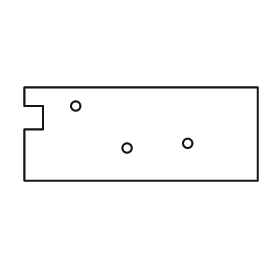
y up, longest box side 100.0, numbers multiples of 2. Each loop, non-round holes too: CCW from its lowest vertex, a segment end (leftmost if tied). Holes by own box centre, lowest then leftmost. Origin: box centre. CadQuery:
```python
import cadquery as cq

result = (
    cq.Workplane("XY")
    .moveTo(-50.0, -20.0)
    .lineTo(50.0, -20.0)
    .lineTo(50.0, 20.0)
    .lineTo(-50.0, 20.0)
    .lineTo(-50.0, 12.0)
    .lineTo(-42.0, 12.0)
    .lineTo(-42.0, 2.0)
    .lineTo(-50.0, 2.0)
    .close()
    .moveTo(-6.0, -6.0)
    .circle(2.0)
    .moveTo(20.0, -4.0)
    .circle(2.0)
    .moveTo(-28.0, 12.0)
    .circle(2.0)
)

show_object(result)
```